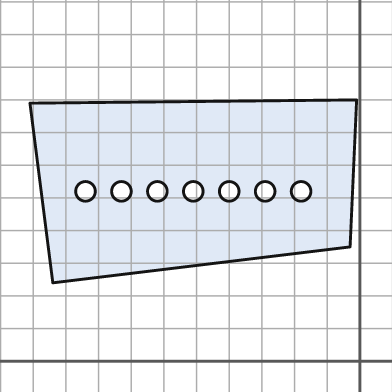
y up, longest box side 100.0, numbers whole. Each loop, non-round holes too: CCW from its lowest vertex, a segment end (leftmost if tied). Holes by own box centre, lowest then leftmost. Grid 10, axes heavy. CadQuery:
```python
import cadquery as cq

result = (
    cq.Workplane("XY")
    .moveTo(-94.0, 24.0)
    .lineTo(-3.0, 35.0)
    .lineTo(-1.0, 80.0)
    .lineTo(-101.0, 79.0)
    .close()
    .moveTo(-84.0, 52.0)
    .circle(3.0)
    .moveTo(-73.0, 52.0)
    .circle(3.0)
    .moveTo(-62.0, 52.0)
    .circle(3.0)
    .moveTo(-51.0, 52.0)
    .circle(3.0)
    .moveTo(-40.0, 52.0)
    .circle(3.0)
    .moveTo(-29.0, 52.0)
    .circle(3.0)
    .moveTo(-18.0, 52.0)
    .circle(3.0)
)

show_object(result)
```